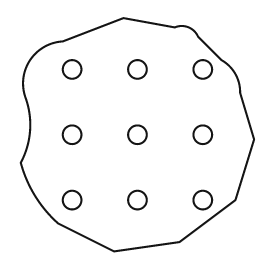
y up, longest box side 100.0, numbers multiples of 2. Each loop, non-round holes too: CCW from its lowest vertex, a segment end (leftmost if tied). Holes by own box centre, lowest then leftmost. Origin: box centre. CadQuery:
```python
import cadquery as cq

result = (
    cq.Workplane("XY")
    .moveTo(-10.0, -50.0)
    .lineTo(18.0, -46.0)
    .lineTo(42.0, -28.0)
    .lineTo(50.0, -2.0)
    .lineTo(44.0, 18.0)
    .threePointArc((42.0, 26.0), (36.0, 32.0))
    .lineTo(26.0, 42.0)
    .threePointArc((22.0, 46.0), (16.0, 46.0))
    .lineTo(-6.0, 50.0)
    .lineTo(-32.0, 40.0)
    .threePointArc((-46.0, 32.0), (-48.0, 16.0))
    .threePointArc((-46.0, 2.0), (-50.0, -12.0))
    .threePointArc((-44.0, -26.0), (-34.0, -38.0))
    .close()
    .moveTo(-28.0, -28.0)
    .circle(4.0)
    .moveTo(0.0, -28.0)
    .circle(4.0)
    .moveTo(28.0, -28.0)
    .circle(4.0)
    .moveTo(-28.0, 0.0)
    .circle(4.0)
    .moveTo(0.0, 0.0)
    .circle(4.0)
    .moveTo(28.0, 0.0)
    .circle(4.0)
    .moveTo(-28.0, 28.0)
    .circle(4.0)
    .moveTo(0.0, 28.0)
    .circle(4.0)
    .moveTo(28.0, 28.0)
    .circle(4.0)
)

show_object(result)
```